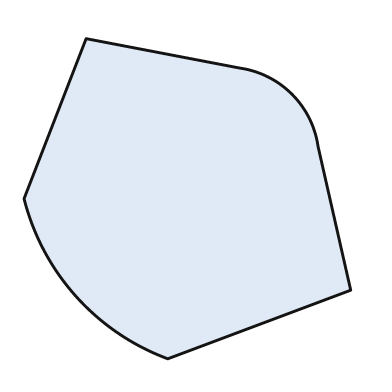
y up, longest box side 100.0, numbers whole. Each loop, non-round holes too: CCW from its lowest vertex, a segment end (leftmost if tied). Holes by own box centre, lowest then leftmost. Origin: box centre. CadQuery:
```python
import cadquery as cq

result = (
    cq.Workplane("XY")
    .moveTo(-6.0, -49.0)
    .lineTo(50.0, -28.0)
    .lineTo(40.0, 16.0)
    .threePointArc((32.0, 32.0), (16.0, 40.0))
    .lineTo(-31.0, 49.0)
    .lineTo(-50.0, 0.0)
    .threePointArc((-34.0, -30.0), (-6.0, -49.0))
    .close()
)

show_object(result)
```